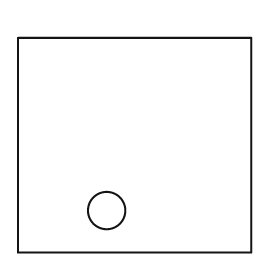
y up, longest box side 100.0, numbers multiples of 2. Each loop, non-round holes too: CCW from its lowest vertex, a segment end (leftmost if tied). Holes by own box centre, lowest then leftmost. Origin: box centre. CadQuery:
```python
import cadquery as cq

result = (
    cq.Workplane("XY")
    .moveTo(-50.0, -46.0)
    .lineTo(50.0, -46.0)
    .lineTo(50.0, 46.0)
    .lineTo(-50.0, 46.0)
    .close()
    .moveTo(-12.0, -28.0)
    .circle(8.0)
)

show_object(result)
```